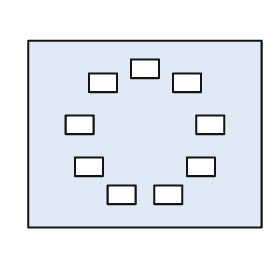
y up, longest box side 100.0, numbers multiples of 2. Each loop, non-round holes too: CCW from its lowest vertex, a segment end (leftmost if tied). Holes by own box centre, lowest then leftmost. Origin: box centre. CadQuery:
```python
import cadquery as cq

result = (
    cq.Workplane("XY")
    .moveTo(-50.0, -40.0)
    .lineTo(50.0, -40.0)
    .lineTo(50.0, 40.0)
    .lineTo(-50.0, 40.0)
    .close()
    .moveTo(-16.0, -30.0)
    .lineTo(-4.0, -30.0)
    .lineTo(-4.0, -22.0)
    .lineTo(-16.0, -22.0)
    .close()
    .moveTo(4.0, -30.0)
    .lineTo(16.0, -30.0)
    .lineTo(16.0, -22.0)
    .lineTo(4.0, -22.0)
    .close()
    .moveTo(-30.0, -18.0)
    .lineTo(-18.0, -18.0)
    .lineTo(-18.0, -10.0)
    .lineTo(-30.0, -10.0)
    .close()
    .moveTo(18.0, -18.0)
    .lineTo(30.0, -18.0)
    .lineTo(30.0, -10.0)
    .lineTo(18.0, -10.0)
    .close()
    .moveTo(-34.0, 0.0)
    .lineTo(-22.0, 0.0)
    .lineTo(-22.0, 8.0)
    .lineTo(-34.0, 8.0)
    .close()
    .moveTo(22.0, 0.0)
    .lineTo(34.0, 0.0)
    .lineTo(34.0, 8.0)
    .lineTo(22.0, 8.0)
    .close()
    .moveTo(-24.0, 18.0)
    .lineTo(-12.0, 18.0)
    .lineTo(-12.0, 26.0)
    .lineTo(-24.0, 26.0)
    .close()
    .moveTo(12.0, 18.0)
    .lineTo(24.0, 18.0)
    .lineTo(24.0, 26.0)
    .lineTo(12.0, 26.0)
    .close()
    .moveTo(-6.0, 24.0)
    .lineTo(6.0, 24.0)
    .lineTo(6.0, 32.0)
    .lineTo(-6.0, 32.0)
    .close()
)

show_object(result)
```